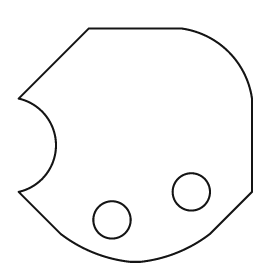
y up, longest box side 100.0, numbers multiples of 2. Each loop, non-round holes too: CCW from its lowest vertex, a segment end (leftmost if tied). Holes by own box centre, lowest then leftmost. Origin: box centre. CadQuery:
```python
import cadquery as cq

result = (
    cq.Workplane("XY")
    .moveTo(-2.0, -50.0)
    .lineTo(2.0, -50.0)
    .threePointArc((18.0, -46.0), (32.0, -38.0))
    .lineTo(50.0, -20.0)
    .lineTo(50.0, 20.0)
    .threePointArc((40.0, 40.0), (20.0, 50.0))
    .lineTo(-20.0, 50.0)
    .lineTo(-50.0, 20.0)
    .threePointArc((-34.0, 0.0), (-50.0, -20.0))
    .lineTo(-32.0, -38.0)
    .threePointArc((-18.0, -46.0), (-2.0, -50.0))
    .close()
    .moveTo(-10.0, -32.0)
    .circle(8.0)
    .moveTo(24.0, -20.0)
    .circle(8.0)
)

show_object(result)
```